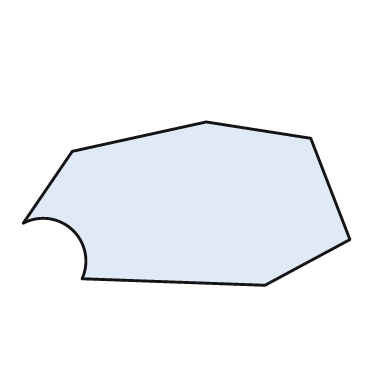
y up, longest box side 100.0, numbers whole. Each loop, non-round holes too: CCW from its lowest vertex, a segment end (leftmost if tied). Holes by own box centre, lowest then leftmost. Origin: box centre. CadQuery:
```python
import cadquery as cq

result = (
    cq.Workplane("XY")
    .moveTo(24.0, -25.0)
    .lineTo(50.0, -11.0)
    .lineTo(38.0, 20.0)
    .lineTo(6.0, 25.0)
    .lineTo(-35.0, 16.0)
    .lineTo(-50.0, -6.0)
    .threePointArc((-35.0, -8.0), (-32.0, -23.0))
    .close()
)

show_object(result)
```